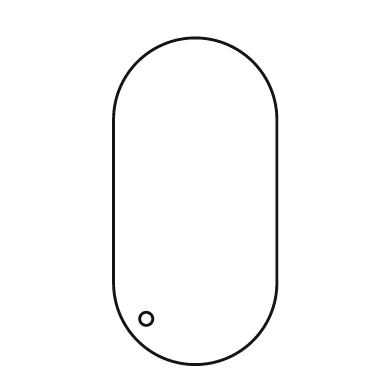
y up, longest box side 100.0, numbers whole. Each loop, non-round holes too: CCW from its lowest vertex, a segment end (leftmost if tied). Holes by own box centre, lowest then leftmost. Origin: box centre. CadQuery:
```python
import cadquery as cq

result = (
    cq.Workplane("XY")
    .moveTo(-25.0, -25.0)
    .threePointArc((0.0, -50.0), (25.0, -25.0))
    .lineTo(25.0, 25.0)
    .threePointArc((0.0, 50.0), (-25.0, 25.0))
    .close()
    .moveTo(-15.0, -36.0)
    .circle(2.0)
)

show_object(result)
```